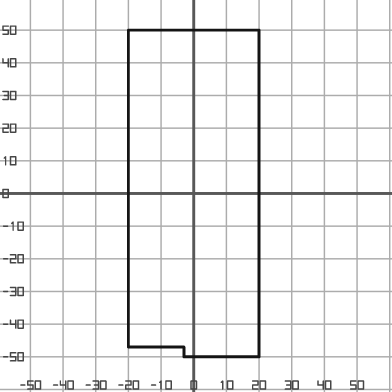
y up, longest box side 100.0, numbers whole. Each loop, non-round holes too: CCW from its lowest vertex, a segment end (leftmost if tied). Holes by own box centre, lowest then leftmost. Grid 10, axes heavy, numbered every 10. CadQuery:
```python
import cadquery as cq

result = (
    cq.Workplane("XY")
    .moveTo(-3.0, -50.0)
    .lineTo(20.0, -50.0)
    .lineTo(20.0, 50.0)
    .lineTo(-20.0, 50.0)
    .lineTo(-20.0, -47.0)
    .lineTo(-3.0, -47.0)
    .close()
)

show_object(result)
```